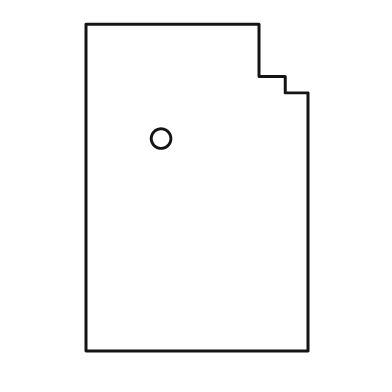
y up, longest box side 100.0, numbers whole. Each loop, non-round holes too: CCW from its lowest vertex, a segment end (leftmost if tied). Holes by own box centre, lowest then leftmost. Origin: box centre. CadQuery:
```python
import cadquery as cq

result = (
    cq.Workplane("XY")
    .moveTo(-34.0, -50.0)
    .lineTo(34.0, -50.0)
    .lineTo(34.0, 29.0)
    .lineTo(27.0, 29.0)
    .lineTo(27.0, 34.0)
    .lineTo(19.0, 34.0)
    .lineTo(19.0, 50.0)
    .lineTo(-34.0, 50.0)
    .close()
    .moveTo(-11.0, 15.0)
    .circle(3.0)
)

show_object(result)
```